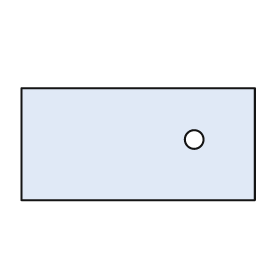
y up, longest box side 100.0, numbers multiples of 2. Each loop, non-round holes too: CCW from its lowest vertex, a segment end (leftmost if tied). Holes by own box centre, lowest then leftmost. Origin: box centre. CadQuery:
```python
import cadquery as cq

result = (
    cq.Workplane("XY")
    .moveTo(-50.0, -24.0)
    .lineTo(50.0, -24.0)
    .lineTo(50.0, 24.0)
    .lineTo(-50.0, 24.0)
    .close()
    .moveTo(24.0, 2.0)
    .circle(4.0)
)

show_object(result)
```